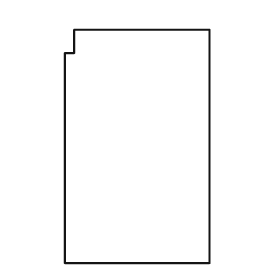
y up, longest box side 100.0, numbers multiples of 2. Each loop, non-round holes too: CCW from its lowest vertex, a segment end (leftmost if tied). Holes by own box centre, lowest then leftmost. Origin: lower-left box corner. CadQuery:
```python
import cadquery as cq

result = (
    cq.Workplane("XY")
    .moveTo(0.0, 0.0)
    .lineTo(62.0, 0.0)
    .lineTo(62.0, 100.0)
    .lineTo(4.0, 100.0)
    .lineTo(4.0, 90.0)
    .lineTo(0.0, 90.0)
    .close()
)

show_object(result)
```